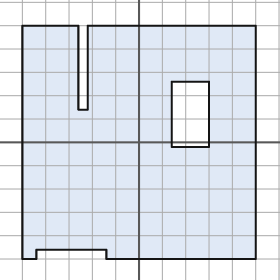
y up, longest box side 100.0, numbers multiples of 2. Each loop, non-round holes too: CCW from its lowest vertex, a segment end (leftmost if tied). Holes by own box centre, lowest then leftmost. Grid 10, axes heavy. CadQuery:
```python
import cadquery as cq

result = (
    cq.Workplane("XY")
    .moveTo(-50.0, -50.0)
    .lineTo(-44.0, -50.0)
    .lineTo(-44.0, -46.0)
    .lineTo(-14.0, -46.0)
    .lineTo(-14.0, -50.0)
    .lineTo(50.0, -50.0)
    .lineTo(50.0, 50.0)
    .lineTo(-22.0, 50.0)
    .lineTo(-22.0, 14.0)
    .lineTo(-26.0, 14.0)
    .lineTo(-26.0, 50.0)
    .lineTo(-50.0, 50.0)
    .close()
    .moveTo(14.0, -2.0)
    .lineTo(30.0, -2.0)
    .lineTo(30.0, 26.0)
    .lineTo(14.0, 26.0)
    .close()
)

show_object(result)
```